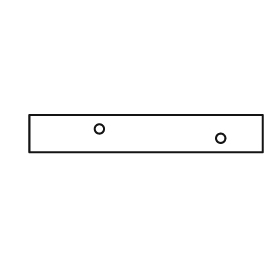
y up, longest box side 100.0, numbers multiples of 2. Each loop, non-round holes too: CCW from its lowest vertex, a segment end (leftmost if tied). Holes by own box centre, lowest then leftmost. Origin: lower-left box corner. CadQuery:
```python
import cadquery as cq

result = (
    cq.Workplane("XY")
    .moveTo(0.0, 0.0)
    .lineTo(100.0, 0.0)
    .lineTo(100.0, 16.0)
    .lineTo(0.0, 16.0)
    .close()
    .moveTo(82.0, 6.0)
    .circle(2.0)
    .moveTo(30.0, 10.0)
    .circle(2.0)
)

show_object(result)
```